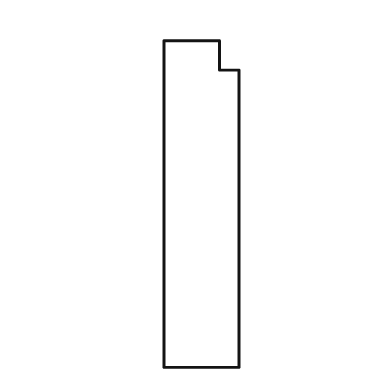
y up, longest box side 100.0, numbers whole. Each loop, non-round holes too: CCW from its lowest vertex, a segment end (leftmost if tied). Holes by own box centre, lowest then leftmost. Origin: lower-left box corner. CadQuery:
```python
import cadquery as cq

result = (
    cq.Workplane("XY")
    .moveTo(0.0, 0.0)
    .lineTo(23.0, 0.0)
    .lineTo(23.0, 91.0)
    .lineTo(17.0, 91.0)
    .lineTo(17.0, 100.0)
    .lineTo(0.0, 100.0)
    .close()
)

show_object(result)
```